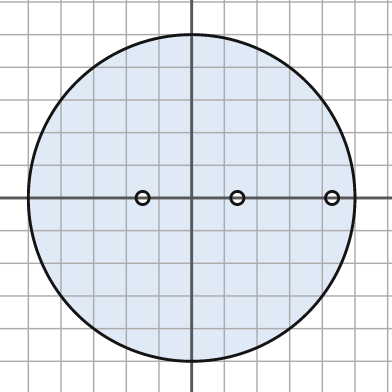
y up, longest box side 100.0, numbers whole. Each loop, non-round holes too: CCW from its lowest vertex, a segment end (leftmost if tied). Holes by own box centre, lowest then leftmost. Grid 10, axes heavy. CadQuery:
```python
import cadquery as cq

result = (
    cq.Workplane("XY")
    .moveTo(0.0, 0.0)
    .circle(50.0)
    .moveTo(-15.0, 0.0)
    .circle(2.0)
    .moveTo(14.0, 0.0)
    .circle(2.0)
    .moveTo(43.0, 0.0)
    .circle(2.0)
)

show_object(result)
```